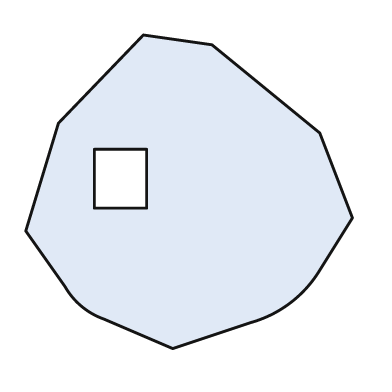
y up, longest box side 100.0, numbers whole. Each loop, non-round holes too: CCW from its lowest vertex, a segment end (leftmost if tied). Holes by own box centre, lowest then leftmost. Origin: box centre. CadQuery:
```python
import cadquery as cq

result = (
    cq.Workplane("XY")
    .moveTo(-5.0, -48.0)
    .lineTo(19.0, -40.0)
    .threePointArc((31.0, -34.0), (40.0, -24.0))
    .lineTo(50.0, -8.0)
    .lineTo(40.0, 18.0)
    .lineTo(7.0, 45.0)
    .lineTo(-14.0, 48.0)
    .lineTo(-40.0, 21.0)
    .lineTo(-50.0, -12.0)
    .lineTo(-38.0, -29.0)
    .threePointArc((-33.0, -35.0), (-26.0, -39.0))
    .close()
    .moveTo(-29.0, -5.0)
    .lineTo(-13.0, -5.0)
    .lineTo(-13.0, 13.0)
    .lineTo(-29.0, 13.0)
    .close()
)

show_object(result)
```